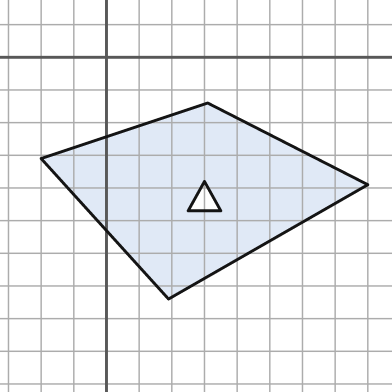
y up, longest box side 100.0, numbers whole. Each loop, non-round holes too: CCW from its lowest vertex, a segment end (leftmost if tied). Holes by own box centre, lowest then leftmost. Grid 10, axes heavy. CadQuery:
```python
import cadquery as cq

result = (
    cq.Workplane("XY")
    .moveTo(19.0, -74.0)
    .lineTo(80.0, -39.0)
    .lineTo(31.0, -14.0)
    .lineTo(-20.0, -31.0)
    .close()
    .moveTo(25.0, -47.0)
    .lineTo(35.0, -47.0)
    .lineTo(30.0, -38.0)
    .close()
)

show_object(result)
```